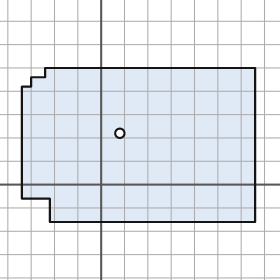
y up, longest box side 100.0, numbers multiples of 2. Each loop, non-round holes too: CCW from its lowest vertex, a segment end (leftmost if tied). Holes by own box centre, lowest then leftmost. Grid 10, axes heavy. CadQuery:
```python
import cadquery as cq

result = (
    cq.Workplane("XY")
    .moveTo(-22.0, -16.0)
    .lineTo(66.0, -16.0)
    .lineTo(66.0, 50.0)
    .lineTo(-24.0, 50.0)
    .lineTo(-24.0, 46.0)
    .lineTo(-30.0, 46.0)
    .lineTo(-30.0, 42.0)
    .lineTo(-34.0, 42.0)
    .lineTo(-34.0, -6.0)
    .lineTo(-22.0, -6.0)
    .close()
    .moveTo(8.0, 22.0)
    .circle(2.0)
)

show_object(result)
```